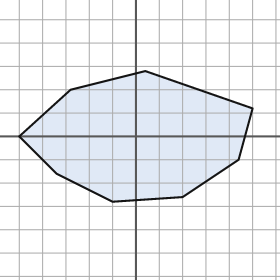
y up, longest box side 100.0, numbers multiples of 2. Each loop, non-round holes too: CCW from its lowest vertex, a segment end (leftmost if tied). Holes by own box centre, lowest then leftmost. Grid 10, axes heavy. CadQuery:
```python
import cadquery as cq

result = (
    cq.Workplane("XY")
    .moveTo(-10.0, -28.0)
    .lineTo(20.0, -26.0)
    .lineTo(44.0, -10.0)
    .lineTo(50.0, 12.0)
    .lineTo(4.0, 28.0)
    .lineTo(-28.0, 20.0)
    .lineTo(-50.0, 0.0)
    .lineTo(-34.0, -16.0)
    .close()
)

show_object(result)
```